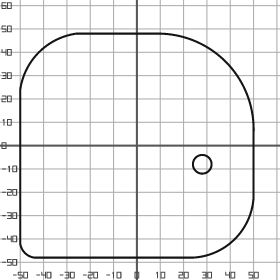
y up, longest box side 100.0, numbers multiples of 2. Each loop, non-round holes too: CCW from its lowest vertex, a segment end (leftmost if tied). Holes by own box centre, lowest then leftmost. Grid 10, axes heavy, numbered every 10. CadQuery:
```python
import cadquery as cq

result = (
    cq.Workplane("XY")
    .moveTo(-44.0, -48.0)
    .lineTo(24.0, -48.0)
    .threePointArc((42.0, -40.0), (50.0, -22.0))
    .lineTo(50.0, 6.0)
    .threePointArc((38.0, 36.0), (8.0, 48.0))
    .lineTo(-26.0, 48.0)
    .threePointArc((-42.0, 40.0), (-50.0, 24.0))
    .lineTo(-50.0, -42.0)
    .threePointArc((-48.0, -46.0), (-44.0, -48.0))
    .close()
    .moveTo(28.0, -8.0)
    .circle(4.0)
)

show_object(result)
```